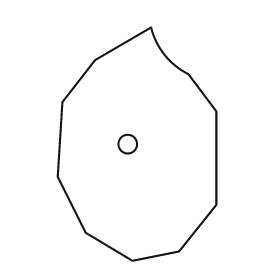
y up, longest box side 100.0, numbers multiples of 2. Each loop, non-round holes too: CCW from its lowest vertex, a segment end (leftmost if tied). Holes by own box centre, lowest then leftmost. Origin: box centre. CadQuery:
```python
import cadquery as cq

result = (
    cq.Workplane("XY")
    .moveTo(-2.0, -50.0)
    .lineTo(18.0, -46.0)
    .lineTo(34.0, -26.0)
    .lineTo(34.0, 14.0)
    .lineTo(22.0, 30.0)
    .threePointArc((12.0, 38.0), (6.0, 50.0))
    .lineTo(-18.0, 36.0)
    .lineTo(-32.0, 18.0)
    .lineTo(-34.0, -14.0)
    .lineTo(-22.0, -38.0)
    .close()
    .moveTo(-4.0, 0.0)
    .circle(4.0)
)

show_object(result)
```